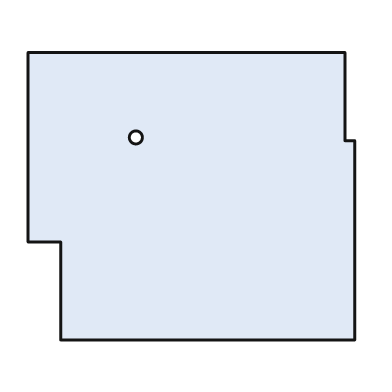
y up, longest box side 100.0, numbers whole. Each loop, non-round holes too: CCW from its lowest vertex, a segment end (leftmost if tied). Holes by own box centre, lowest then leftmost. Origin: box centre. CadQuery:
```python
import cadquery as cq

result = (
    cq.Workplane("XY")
    .moveTo(-40.0, -44.0)
    .lineTo(50.0, -44.0)
    .lineTo(50.0, 17.0)
    .lineTo(47.0, 17.0)
    .lineTo(47.0, 44.0)
    .lineTo(-50.0, 44.0)
    .lineTo(-50.0, -14.0)
    .lineTo(-40.0, -14.0)
    .close()
    .moveTo(-17.0, 18.0)
    .circle(2.0)
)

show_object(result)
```